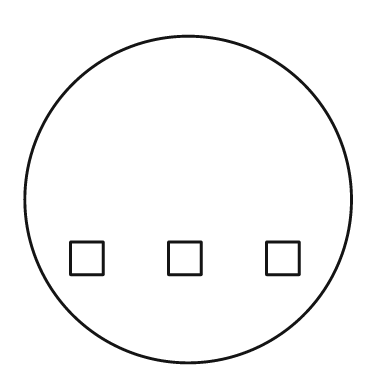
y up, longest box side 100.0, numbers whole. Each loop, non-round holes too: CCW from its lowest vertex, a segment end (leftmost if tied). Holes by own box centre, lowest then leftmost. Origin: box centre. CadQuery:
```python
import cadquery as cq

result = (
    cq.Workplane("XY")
    .moveTo(0.0, 0.0)
    .circle(50.0)
    .moveTo(-36.0, -23.0)
    .lineTo(-26.0, -23.0)
    .lineTo(-26.0, -13.0)
    .lineTo(-36.0, -13.0)
    .close()
    .moveTo(-6.0, -23.0)
    .lineTo(4.0, -23.0)
    .lineTo(4.0, -13.0)
    .lineTo(-6.0, -13.0)
    .close()
    .moveTo(24.0, -23.0)
    .lineTo(34.0, -23.0)
    .lineTo(34.0, -13.0)
    .lineTo(24.0, -13.0)
    .close()
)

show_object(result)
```